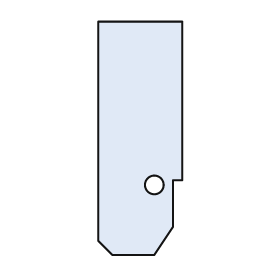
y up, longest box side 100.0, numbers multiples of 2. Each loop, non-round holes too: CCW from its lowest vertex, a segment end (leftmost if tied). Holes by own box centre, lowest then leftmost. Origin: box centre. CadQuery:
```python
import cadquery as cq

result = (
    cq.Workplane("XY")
    .moveTo(-12.0, -50.0)
    .lineTo(6.0, -50.0)
    .lineTo(14.0, -38.0)
    .lineTo(14.0, -18.0)
    .lineTo(18.0, -18.0)
    .lineTo(18.0, 50.0)
    .lineTo(-18.0, 50.0)
    .lineTo(-18.0, -44.0)
    .close()
    .moveTo(6.0, -20.0)
    .circle(4.0)
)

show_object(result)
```